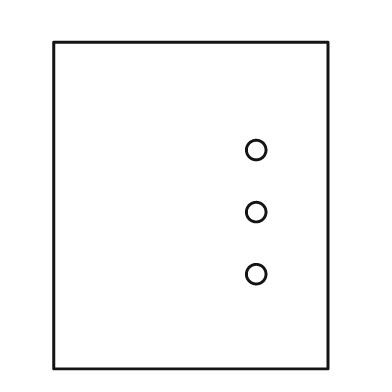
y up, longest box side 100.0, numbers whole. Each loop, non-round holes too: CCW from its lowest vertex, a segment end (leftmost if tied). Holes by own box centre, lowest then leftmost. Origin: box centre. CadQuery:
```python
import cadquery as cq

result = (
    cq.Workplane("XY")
    .moveTo(-42.0, -50.0)
    .lineTo(42.0, -50.0)
    .lineTo(42.0, 50.0)
    .lineTo(-42.0, 50.0)
    .close()
    .moveTo(20.0, -21.0)
    .circle(3.0)
    .moveTo(20.0, -2.0)
    .circle(3.0)
    .moveTo(20.0, 17.0)
    .circle(3.0)
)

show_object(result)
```